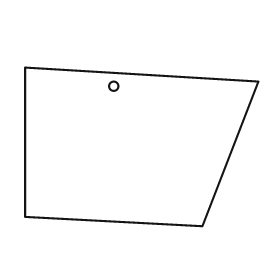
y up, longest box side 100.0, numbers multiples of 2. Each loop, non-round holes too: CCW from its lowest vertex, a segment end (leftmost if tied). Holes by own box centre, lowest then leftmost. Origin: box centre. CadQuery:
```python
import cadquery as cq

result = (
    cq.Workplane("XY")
    .moveTo(26.0, -34.0)
    .lineTo(50.0, 28.0)
    .lineTo(-50.0, 34.0)
    .lineTo(-50.0, -30.0)
    .close()
    .moveTo(-12.0, 26.0)
    .circle(2.0)
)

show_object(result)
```